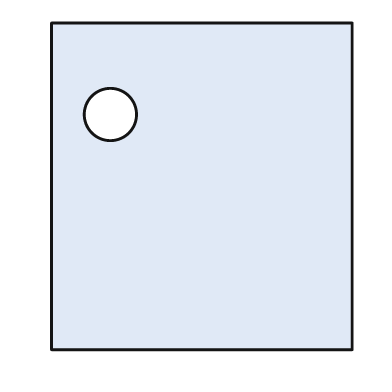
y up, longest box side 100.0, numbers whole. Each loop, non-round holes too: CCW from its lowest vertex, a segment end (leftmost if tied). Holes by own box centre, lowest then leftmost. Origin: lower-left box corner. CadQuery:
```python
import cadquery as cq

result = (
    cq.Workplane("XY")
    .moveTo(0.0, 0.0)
    .lineTo(92.0, 0.0)
    .lineTo(92.0, 100.0)
    .lineTo(0.0, 100.0)
    .close()
    .moveTo(18.0, 72.0)
    .circle(8.0)
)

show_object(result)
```